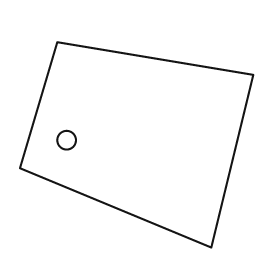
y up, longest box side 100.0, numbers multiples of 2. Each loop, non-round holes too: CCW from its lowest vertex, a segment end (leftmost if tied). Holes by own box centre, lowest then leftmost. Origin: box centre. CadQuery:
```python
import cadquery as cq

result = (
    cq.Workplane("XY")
    .moveTo(32.0, -44.0)
    .lineTo(50.0, 30.0)
    .lineTo(-34.0, 44.0)
    .lineTo(-50.0, -10.0)
    .close()
    .moveTo(-30.0, 2.0)
    .circle(4.0)
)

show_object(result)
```